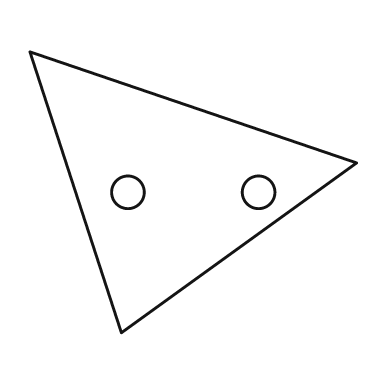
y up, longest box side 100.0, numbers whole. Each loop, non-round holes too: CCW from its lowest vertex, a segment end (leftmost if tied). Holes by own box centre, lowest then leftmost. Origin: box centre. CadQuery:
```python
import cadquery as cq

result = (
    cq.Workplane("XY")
    .moveTo(-22.0, -43.0)
    .lineTo(50.0, 9.0)
    .lineTo(-50.0, 43.0)
    .close()
    .moveTo(-20.0, 0.0)
    .circle(5.0)
    .moveTo(20.0, 0.0)
    .circle(5.0)
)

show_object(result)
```